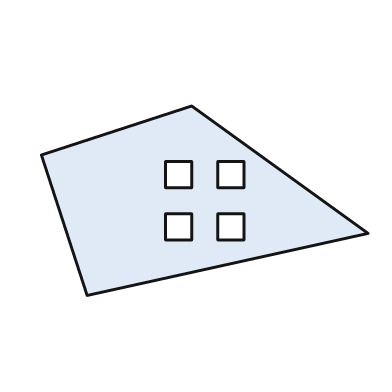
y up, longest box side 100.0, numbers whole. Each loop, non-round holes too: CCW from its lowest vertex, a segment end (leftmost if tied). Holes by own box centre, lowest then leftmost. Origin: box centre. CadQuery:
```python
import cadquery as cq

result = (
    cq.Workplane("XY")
    .moveTo(-36.0, -29.0)
    .lineTo(50.0, -10.0)
    .lineTo(-4.0, 29.0)
    .lineTo(-50.0, 14.0)
    .close()
    .moveTo(-12.0, -12.0)
    .lineTo(-4.0, -12.0)
    .lineTo(-4.0, -4.0)
    .lineTo(-12.0, -4.0)
    .close()
    .moveTo(4.0, -12.0)
    .lineTo(12.0, -12.0)
    .lineTo(12.0, -4.0)
    .lineTo(4.0, -4.0)
    .close()
    .moveTo(-12.0, 4.0)
    .lineTo(-4.0, 4.0)
    .lineTo(-4.0, 12.0)
    .lineTo(-12.0, 12.0)
    .close()
    .moveTo(4.0, 4.0)
    .lineTo(12.0, 4.0)
    .lineTo(12.0, 12.0)
    .lineTo(4.0, 12.0)
    .close()
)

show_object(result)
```